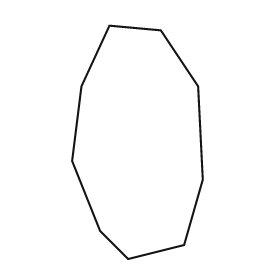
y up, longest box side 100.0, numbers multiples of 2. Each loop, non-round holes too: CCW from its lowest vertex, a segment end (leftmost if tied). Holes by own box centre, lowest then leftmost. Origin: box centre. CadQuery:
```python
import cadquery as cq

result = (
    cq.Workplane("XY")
    .moveTo(-4.0, -50.0)
    .lineTo(20.0, -44.0)
    .lineTo(28.0, -16.0)
    .lineTo(26.0, 24.0)
    .lineTo(10.0, 48.0)
    .lineTo(-12.0, 50.0)
    .lineTo(-24.0, 24.0)
    .lineTo(-28.0, -8.0)
    .lineTo(-16.0, -38.0)
    .close()
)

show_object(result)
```